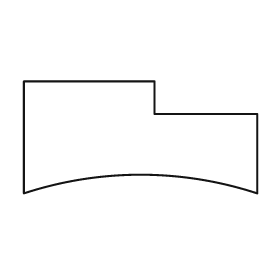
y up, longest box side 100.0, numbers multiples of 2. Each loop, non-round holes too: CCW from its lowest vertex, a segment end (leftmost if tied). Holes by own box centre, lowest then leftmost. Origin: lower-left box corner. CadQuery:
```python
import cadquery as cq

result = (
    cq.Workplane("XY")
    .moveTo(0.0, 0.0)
    .threePointArc((50.0, 8.0), (100.0, 0.0))
    .lineTo(100.0, 34.0)
    .lineTo(56.0, 34.0)
    .lineTo(56.0, 48.0)
    .lineTo(0.0, 48.0)
    .close()
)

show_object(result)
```